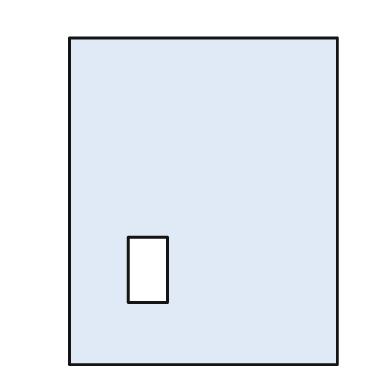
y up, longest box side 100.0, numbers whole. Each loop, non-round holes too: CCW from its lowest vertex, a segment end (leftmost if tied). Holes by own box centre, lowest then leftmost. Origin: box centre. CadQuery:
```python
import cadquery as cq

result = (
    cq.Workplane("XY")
    .moveTo(-41.0, -50.0)
    .lineTo(41.0, -50.0)
    .lineTo(41.0, 50.0)
    .lineTo(-41.0, 50.0)
    .close()
    .moveTo(-23.0, -31.0)
    .lineTo(-11.0, -31.0)
    .lineTo(-11.0, -11.0)
    .lineTo(-23.0, -11.0)
    .close()
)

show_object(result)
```